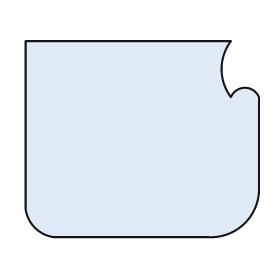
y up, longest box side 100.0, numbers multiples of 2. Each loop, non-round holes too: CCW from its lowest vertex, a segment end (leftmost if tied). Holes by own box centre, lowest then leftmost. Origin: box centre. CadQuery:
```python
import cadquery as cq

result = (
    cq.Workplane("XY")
    .moveTo(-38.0, -42.0)
    .lineTo(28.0, -42.0)
    .threePointArc((44.0, -36.0), (50.0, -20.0))
    .lineTo(50.0, 18.0)
    .threePointArc((44.0, 22.0), (38.0, 18.0))
    .threePointArc((34.0, 30.0), (38.0, 42.0))
    .lineTo(-50.0, 42.0)
    .lineTo(-50.0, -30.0)
    .threePointArc((-46.0, -38.0), (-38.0, -42.0))
    .close()
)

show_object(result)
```